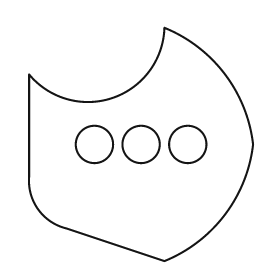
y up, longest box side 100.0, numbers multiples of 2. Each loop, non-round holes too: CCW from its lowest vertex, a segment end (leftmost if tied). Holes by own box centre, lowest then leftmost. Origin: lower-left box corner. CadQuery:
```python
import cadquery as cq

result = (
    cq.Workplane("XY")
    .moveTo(58.0, 0.0)
    .threePointArc((84.0, 20.0), (96.0, 50.0))
    .threePointArc((84.0, 80.0), (58.0, 100.0))
    .threePointArc((36.0, 70.0), (0.0, 80.0))
    .lineTo(0.0, 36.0)
    .threePointArc((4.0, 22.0), (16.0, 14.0))
    .close()
    .moveTo(28.0, 50.0)
    .circle(8.0)
    .moveTo(48.0, 50.0)
    .circle(8.0)
    .moveTo(68.0, 50.0)
    .circle(8.0)
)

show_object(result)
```